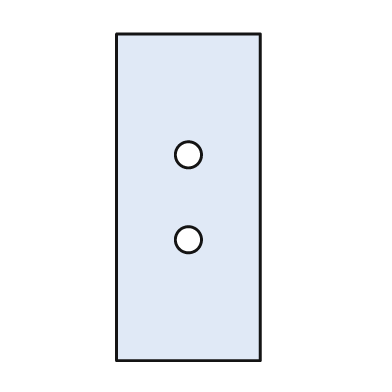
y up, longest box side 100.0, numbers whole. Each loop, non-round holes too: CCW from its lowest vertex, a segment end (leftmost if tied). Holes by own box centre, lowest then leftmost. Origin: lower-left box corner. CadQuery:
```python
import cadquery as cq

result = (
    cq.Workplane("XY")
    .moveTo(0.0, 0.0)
    .lineTo(44.0, 0.0)
    .lineTo(44.0, 100.0)
    .lineTo(0.0, 100.0)
    .close()
    .moveTo(22.0, 37.0)
    .circle(4.0)
    .moveTo(22.0, 63.0)
    .circle(4.0)
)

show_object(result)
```